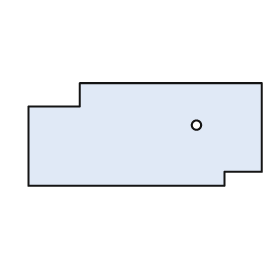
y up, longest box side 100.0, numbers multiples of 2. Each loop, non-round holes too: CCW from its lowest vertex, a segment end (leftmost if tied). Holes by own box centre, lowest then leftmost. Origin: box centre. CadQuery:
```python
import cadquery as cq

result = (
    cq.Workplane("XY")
    .moveTo(-50.0, -22.0)
    .lineTo(34.0, -22.0)
    .lineTo(34.0, -16.0)
    .lineTo(50.0, -16.0)
    .lineTo(50.0, 22.0)
    .lineTo(-28.0, 22.0)
    .lineTo(-28.0, 12.0)
    .lineTo(-50.0, 12.0)
    .close()
    .moveTo(22.0, 4.0)
    .circle(2.0)
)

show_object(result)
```